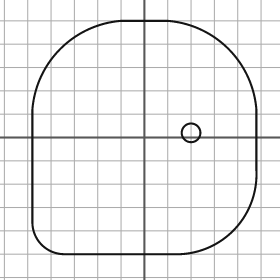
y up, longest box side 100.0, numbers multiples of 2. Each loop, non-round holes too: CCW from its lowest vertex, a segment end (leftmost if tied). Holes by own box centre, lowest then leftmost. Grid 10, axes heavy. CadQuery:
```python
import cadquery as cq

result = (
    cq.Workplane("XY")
    .moveTo(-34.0, -50.0)
    .lineTo(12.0, -50.0)
    .threePointArc((38.0, -40.0), (48.0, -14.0))
    .lineTo(48.0, 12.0)
    .threePointArc((36.0, 38.0), (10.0, 50.0))
    .lineTo(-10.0, 50.0)
    .threePointArc((-36.0, 38.0), (-48.0, 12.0))
    .lineTo(-48.0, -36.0)
    .threePointArc((-44.0, -46.0), (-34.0, -50.0))
    .close()
    .moveTo(20.0, 2.0)
    .circle(4.0)
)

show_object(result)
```